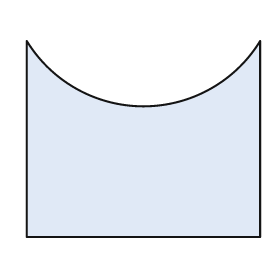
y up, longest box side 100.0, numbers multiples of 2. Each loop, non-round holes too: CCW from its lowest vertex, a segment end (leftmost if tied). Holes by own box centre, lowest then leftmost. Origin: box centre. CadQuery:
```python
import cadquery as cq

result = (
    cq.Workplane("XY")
    .moveTo(-50.0, -42.0)
    .lineTo(50.0, -42.0)
    .lineTo(50.0, 42.0)
    .threePointArc((0.0, 14.0), (-50.0, 42.0))
    .close()
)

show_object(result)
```